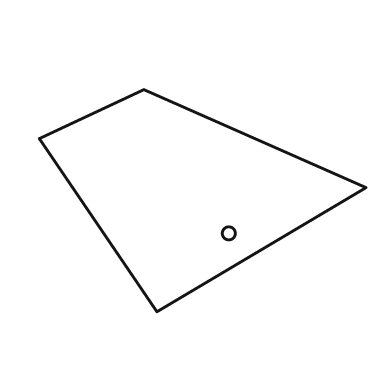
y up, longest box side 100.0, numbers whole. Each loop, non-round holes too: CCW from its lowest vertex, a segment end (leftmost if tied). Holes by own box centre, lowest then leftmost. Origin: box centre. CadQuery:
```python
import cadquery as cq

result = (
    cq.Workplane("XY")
    .moveTo(-14.0, -34.0)
    .lineTo(50.0, 4.0)
    .lineTo(-18.0, 34.0)
    .lineTo(-50.0, 19.0)
    .close()
    .moveTo(8.0, -10.0)
    .circle(2.0)
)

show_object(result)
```